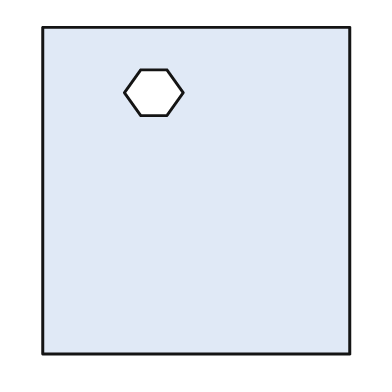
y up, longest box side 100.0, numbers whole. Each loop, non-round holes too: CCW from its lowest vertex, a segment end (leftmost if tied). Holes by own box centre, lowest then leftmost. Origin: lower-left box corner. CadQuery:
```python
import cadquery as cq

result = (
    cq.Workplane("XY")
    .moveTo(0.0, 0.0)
    .lineTo(94.0, 0.0)
    .lineTo(94.0, 100.0)
    .lineTo(0.0, 100.0)
    .close()
    .moveTo(30.0, 73.0)
    .lineTo(38.0, 73.0)
    .lineTo(43.0, 80.0)
    .lineTo(38.0, 87.0)
    .lineTo(30.0, 87.0)
    .lineTo(25.0, 80.0)
    .close()
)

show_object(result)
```